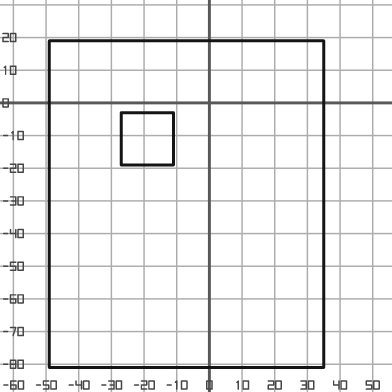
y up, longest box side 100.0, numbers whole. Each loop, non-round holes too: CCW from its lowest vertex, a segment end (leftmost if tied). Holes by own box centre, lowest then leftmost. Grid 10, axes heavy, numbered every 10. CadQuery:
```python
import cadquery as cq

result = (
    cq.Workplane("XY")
    .moveTo(-49.0, -81.0)
    .lineTo(35.0, -81.0)
    .lineTo(35.0, 19.0)
    .lineTo(-49.0, 19.0)
    .close()
    .moveTo(-27.0, -19.0)
    .lineTo(-11.0, -19.0)
    .lineTo(-11.0, -3.0)
    .lineTo(-27.0, -3.0)
    .close()
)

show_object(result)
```